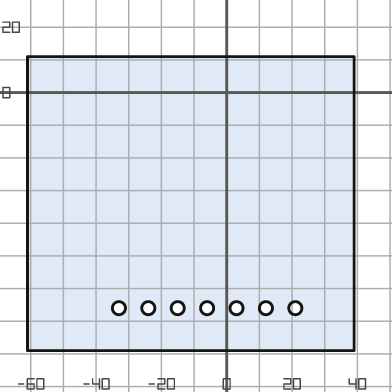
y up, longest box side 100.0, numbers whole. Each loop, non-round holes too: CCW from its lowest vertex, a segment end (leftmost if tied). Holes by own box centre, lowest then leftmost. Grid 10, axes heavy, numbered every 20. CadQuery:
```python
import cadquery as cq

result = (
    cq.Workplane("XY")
    .moveTo(-61.0, -79.0)
    .lineTo(39.0, -79.0)
    .lineTo(39.0, 11.0)
    .lineTo(-61.0, 11.0)
    .close()
    .moveTo(-33.0, -66.0)
    .circle(2.0)
    .moveTo(-24.0, -66.0)
    .circle(2.0)
    .moveTo(-15.0, -66.0)
    .circle(2.0)
    .moveTo(-6.0, -66.0)
    .circle(2.0)
    .moveTo(3.0, -66.0)
    .circle(2.0)
    .moveTo(12.0, -66.0)
    .circle(2.0)
    .moveTo(21.0, -66.0)
    .circle(2.0)
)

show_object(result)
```